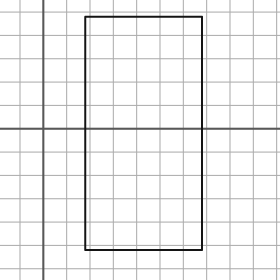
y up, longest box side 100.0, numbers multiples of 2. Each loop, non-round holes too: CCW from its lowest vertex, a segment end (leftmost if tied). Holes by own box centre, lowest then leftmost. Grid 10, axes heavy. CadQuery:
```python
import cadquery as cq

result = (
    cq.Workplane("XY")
    .moveTo(18.0, -52.0)
    .lineTo(68.0, -52.0)
    .lineTo(68.0, 48.0)
    .lineTo(18.0, 48.0)
    .close()
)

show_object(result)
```